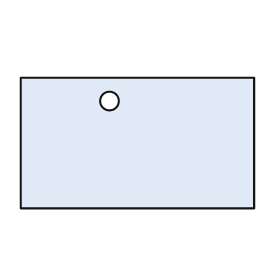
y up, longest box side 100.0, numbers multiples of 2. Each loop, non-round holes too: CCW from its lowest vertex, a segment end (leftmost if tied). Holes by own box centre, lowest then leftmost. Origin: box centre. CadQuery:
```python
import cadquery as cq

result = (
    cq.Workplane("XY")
    .moveTo(-50.0, -28.0)
    .lineTo(50.0, -28.0)
    .lineTo(50.0, 28.0)
    .lineTo(-50.0, 28.0)
    .close()
    .moveTo(-12.0, 18.0)
    .circle(4.0)
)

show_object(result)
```